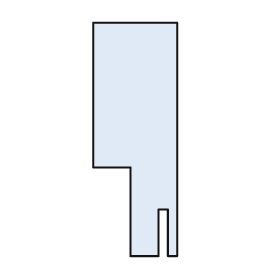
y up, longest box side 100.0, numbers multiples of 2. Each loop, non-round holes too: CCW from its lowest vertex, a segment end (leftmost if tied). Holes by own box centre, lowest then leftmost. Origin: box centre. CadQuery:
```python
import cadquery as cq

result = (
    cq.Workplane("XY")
    .moveTo(-2.0, -50.0)
    .lineTo(10.0, -50.0)
    .lineTo(10.0, -30.0)
    .lineTo(14.0, -30.0)
    .lineTo(14.0, -50.0)
    .lineTo(18.0, -50.0)
    .lineTo(18.0, 50.0)
    .lineTo(-18.0, 50.0)
    .lineTo(-18.0, -12.0)
    .lineTo(-2.0, -12.0)
    .close()
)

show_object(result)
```